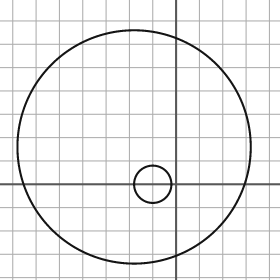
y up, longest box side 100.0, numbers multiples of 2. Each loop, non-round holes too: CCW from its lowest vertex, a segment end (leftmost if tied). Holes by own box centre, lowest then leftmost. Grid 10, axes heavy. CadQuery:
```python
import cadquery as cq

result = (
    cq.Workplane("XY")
    .moveTo(-18.0, 16.0)
    .circle(50.0)
    .moveTo(-10.0, 0.0)
    .circle(8.0)
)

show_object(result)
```